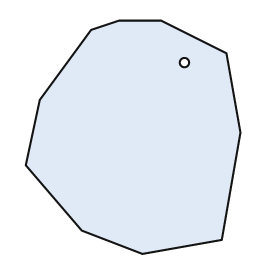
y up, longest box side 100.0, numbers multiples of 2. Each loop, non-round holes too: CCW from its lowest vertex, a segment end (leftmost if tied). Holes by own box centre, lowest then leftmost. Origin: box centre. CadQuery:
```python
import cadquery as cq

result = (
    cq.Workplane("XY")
    .moveTo(4.0, -50.0)
    .lineTo(38.0, -44.0)
    .lineTo(46.0, 2.0)
    .lineTo(40.0, 36.0)
    .lineTo(12.0, 50.0)
    .lineTo(-6.0, 50.0)
    .lineTo(-18.0, 46.0)
    .lineTo(-40.0, 16.0)
    .lineTo(-46.0, -12.0)
    .lineTo(-22.0, -40.0)
    .close()
    .moveTo(22.0, 32.0)
    .circle(2.0)
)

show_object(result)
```